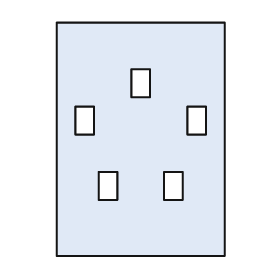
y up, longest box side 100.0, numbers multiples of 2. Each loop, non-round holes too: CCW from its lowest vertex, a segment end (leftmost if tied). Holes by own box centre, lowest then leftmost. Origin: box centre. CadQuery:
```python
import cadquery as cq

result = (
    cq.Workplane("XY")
    .moveTo(-36.0, -50.0)
    .lineTo(36.0, -50.0)
    .lineTo(36.0, 50.0)
    .lineTo(-36.0, 50.0)
    .close()
    .moveTo(-18.0, -26.0)
    .lineTo(-10.0, -26.0)
    .lineTo(-10.0, -14.0)
    .lineTo(-18.0, -14.0)
    .close()
    .moveTo(10.0, -26.0)
    .lineTo(18.0, -26.0)
    .lineTo(18.0, -14.0)
    .lineTo(10.0, -14.0)
    .close()
    .moveTo(-28.0, 2.0)
    .lineTo(-20.0, 2.0)
    .lineTo(-20.0, 14.0)
    .lineTo(-28.0, 14.0)
    .close()
    .moveTo(20.0, 2.0)
    .lineTo(28.0, 2.0)
    .lineTo(28.0, 14.0)
    .lineTo(20.0, 14.0)
    .close()
    .moveTo(-4.0, 18.0)
    .lineTo(4.0, 18.0)
    .lineTo(4.0, 30.0)
    .lineTo(-4.0, 30.0)
    .close()
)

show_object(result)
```